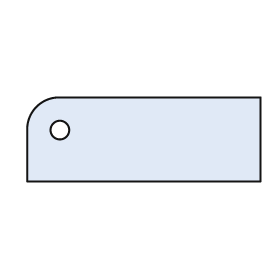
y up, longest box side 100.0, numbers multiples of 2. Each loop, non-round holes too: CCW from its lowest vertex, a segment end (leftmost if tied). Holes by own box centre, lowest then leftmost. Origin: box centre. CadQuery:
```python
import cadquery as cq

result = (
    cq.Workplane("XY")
    .moveTo(-50.0, -18.0)
    .lineTo(50.0, -18.0)
    .lineTo(50.0, 18.0)
    .lineTo(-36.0, 18.0)
    .threePointArc((-46.0, 14.0), (-50.0, 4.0))
    .close()
    .moveTo(-36.0, 4.0)
    .circle(4.0)
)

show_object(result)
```